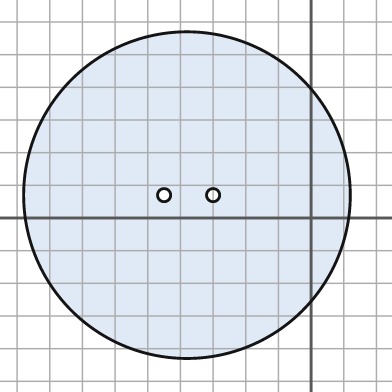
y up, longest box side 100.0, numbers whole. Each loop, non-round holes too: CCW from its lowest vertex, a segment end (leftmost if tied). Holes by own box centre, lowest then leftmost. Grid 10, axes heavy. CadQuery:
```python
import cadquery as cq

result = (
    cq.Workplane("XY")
    .moveTo(-38.0, 7.0)
    .circle(50.0)
    .moveTo(-45.0, 7.0)
    .circle(2.0)
    .moveTo(-30.0, 7.0)
    .circle(2.0)
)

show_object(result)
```